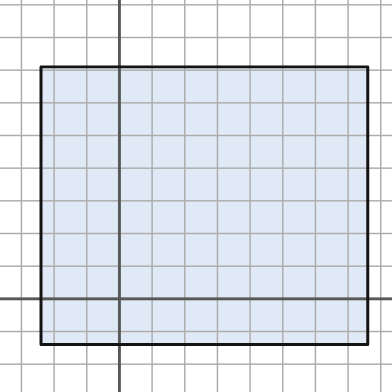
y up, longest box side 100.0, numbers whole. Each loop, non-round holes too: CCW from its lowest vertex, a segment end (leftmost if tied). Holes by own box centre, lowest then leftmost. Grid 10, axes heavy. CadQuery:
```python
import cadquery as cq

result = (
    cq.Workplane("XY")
    .moveTo(-24.0, -14.0)
    .lineTo(76.0, -14.0)
    .lineTo(76.0, 71.0)
    .lineTo(-24.0, 71.0)
    .close()
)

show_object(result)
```